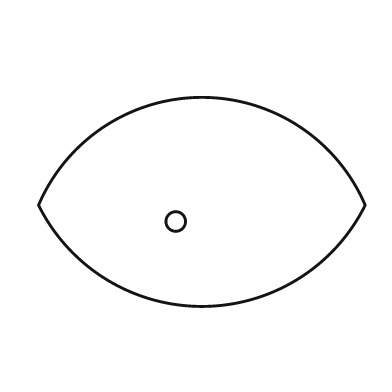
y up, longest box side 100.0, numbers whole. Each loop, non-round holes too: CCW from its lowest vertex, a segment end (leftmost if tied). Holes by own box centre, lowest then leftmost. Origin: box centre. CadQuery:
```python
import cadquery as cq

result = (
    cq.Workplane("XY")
    .moveTo(-50.0, -1.0)
    .threePointArc((0.0, -32.0), (50.0, -1.0))
    .threePointArc((0.0, 32.0), (-50.0, -1.0))
    .close()
    .moveTo(-8.0, -6.0)
    .circle(3.0)
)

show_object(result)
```